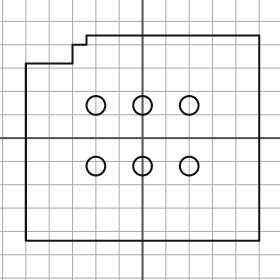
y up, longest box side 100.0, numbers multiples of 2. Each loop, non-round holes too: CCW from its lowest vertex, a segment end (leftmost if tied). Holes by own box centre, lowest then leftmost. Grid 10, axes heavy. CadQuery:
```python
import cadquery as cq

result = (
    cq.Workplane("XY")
    .moveTo(-50.0, -44.0)
    .lineTo(50.0, -44.0)
    .lineTo(50.0, 44.0)
    .lineTo(-24.0, 44.0)
    .lineTo(-24.0, 40.0)
    .lineTo(-30.0, 40.0)
    .lineTo(-30.0, 32.0)
    .lineTo(-50.0, 32.0)
    .close()
    .moveTo(-20.0, -12.0)
    .circle(4.0)
    .moveTo(0.0, -12.0)
    .circle(4.0)
    .moveTo(20.0, -12.0)
    .circle(4.0)
    .moveTo(-20.0, 14.0)
    .circle(4.0)
    .moveTo(0.0, 14.0)
    .circle(4.0)
    .moveTo(20.0, 14.0)
    .circle(4.0)
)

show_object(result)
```